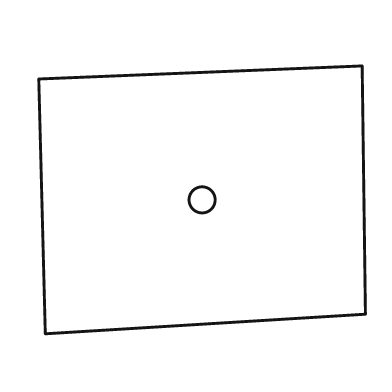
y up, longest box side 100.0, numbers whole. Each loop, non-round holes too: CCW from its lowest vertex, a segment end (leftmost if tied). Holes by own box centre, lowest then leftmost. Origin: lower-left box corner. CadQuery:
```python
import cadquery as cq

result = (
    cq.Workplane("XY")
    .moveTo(2.0, 0.0)
    .lineTo(100.0, 6.0)
    .lineTo(99.0, 82.0)
    .lineTo(0.0, 78.0)
    .close()
    .moveTo(50.0, 41.0)
    .circle(4.0)
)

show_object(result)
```